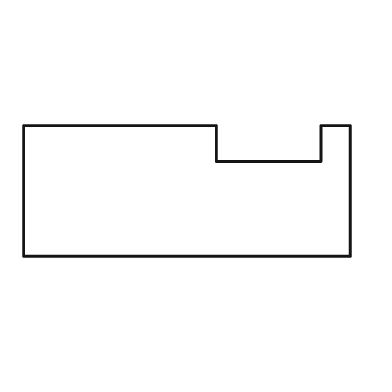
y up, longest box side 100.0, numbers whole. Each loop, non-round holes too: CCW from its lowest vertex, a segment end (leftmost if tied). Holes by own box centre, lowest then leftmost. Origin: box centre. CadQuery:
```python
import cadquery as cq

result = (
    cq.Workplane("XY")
    .moveTo(-50.0, -20.0)
    .lineTo(50.0, -20.0)
    .lineTo(50.0, 20.0)
    .lineTo(41.0, 20.0)
    .lineTo(41.0, 9.0)
    .lineTo(9.0, 9.0)
    .lineTo(9.0, 20.0)
    .lineTo(-50.0, 20.0)
    .close()
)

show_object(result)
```